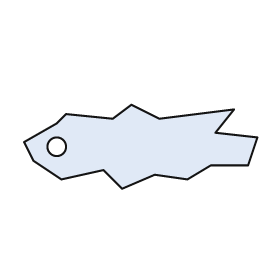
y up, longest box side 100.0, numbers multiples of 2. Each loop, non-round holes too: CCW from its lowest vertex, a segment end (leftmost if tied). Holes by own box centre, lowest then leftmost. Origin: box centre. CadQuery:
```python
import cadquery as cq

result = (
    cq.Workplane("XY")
    .moveTo(-8.0, -18.0)
    .lineTo(6.0, -12.0)
    .lineTo(20.0, -14.0)
    .lineTo(30.0, -8.0)
    .lineTo(46.0, -8.0)
    .lineTo(50.0, 4.0)
    .lineTo(32.0, 6.0)
    .lineTo(40.0, 16.0)
    .lineTo(8.0, 12.0)
    .lineTo(-4.0, 18.0)
    .lineTo(-12.0, 12.0)
    .lineTo(-32.0, 14.0)
    .lineTo(-36.0, 10.0)
    .lineTo(-50.0, 2.0)
    .lineTo(-46.0, -6.0)
    .lineTo(-34.0, -14.0)
    .lineTo(-16.0, -10.0)
    .close()
    .moveTo(-36.0, 0.0)
    .circle(4.0)
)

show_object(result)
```